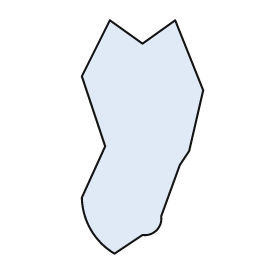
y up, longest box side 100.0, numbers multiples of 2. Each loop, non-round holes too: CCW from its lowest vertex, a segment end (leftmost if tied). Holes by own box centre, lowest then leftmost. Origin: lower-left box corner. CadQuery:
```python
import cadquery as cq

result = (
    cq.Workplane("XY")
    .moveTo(14.0, 0.0)
    .lineTo(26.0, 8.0)
    .threePointArc((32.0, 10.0), (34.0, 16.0))
    .lineTo(42.0, 38.0)
    .lineTo(46.0, 44.0)
    .lineTo(52.0, 70.0)
    .lineTo(40.0, 100.0)
    .lineTo(26.0, 90.0)
    .lineTo(12.0, 100.0)
    .lineTo(0.0, 76.0)
    .lineTo(10.0, 46.0)
    .lineTo(0.0, 24.0)
    .threePointArc((4.0, 10.0), (14.0, 0.0))
    .close()
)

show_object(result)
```